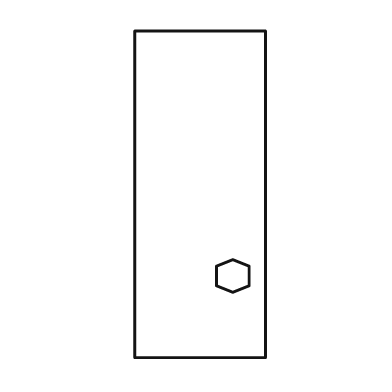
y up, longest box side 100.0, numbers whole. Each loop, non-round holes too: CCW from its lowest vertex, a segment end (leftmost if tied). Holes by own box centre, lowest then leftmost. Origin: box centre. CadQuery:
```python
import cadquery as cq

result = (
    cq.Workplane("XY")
    .moveTo(-20.0, -50.0)
    .lineTo(20.0, -50.0)
    .lineTo(20.0, 50.0)
    .lineTo(-20.0, 50.0)
    .close()
    .moveTo(10.0, -30.0)
    .lineTo(15.0, -28.0)
    .lineTo(15.0, -22.0)
    .lineTo(10.0, -20.0)
    .lineTo(5.0, -22.0)
    .lineTo(5.0, -28.0)
    .close()
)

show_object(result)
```